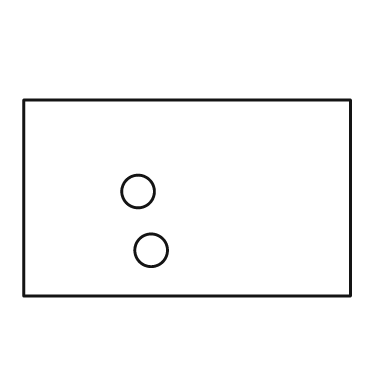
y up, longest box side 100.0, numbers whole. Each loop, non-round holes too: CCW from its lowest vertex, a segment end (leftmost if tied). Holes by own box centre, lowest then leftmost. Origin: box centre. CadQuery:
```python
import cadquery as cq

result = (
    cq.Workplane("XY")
    .moveTo(-50.0, -30.0)
    .lineTo(50.0, -30.0)
    .lineTo(50.0, 30.0)
    .lineTo(-50.0, 30.0)
    .close()
    .moveTo(-11.0, -16.0)
    .circle(5.0)
    .moveTo(-15.0, 2.0)
    .circle(5.0)
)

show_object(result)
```